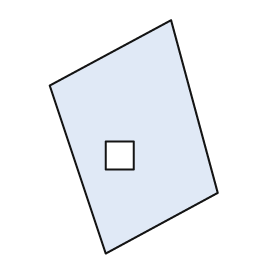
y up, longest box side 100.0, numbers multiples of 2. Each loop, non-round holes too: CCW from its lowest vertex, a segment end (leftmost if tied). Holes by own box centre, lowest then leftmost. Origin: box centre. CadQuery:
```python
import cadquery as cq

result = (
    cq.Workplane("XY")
    .moveTo(-12.0, -50.0)
    .lineTo(36.0, -24.0)
    .lineTo(16.0, 50.0)
    .lineTo(-36.0, 22.0)
    .close()
    .moveTo(-12.0, -14.0)
    .lineTo(0.0, -14.0)
    .lineTo(0.0, -2.0)
    .lineTo(-12.0, -2.0)
    .close()
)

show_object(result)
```